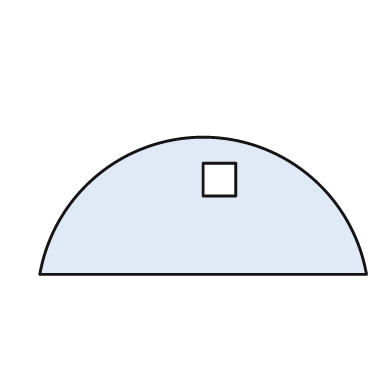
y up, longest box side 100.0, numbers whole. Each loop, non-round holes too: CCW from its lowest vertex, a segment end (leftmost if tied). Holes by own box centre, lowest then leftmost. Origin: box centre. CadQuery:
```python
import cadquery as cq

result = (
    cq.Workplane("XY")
    .moveTo(-50.0, -21.0)
    .lineTo(50.0, -21.0)
    .threePointArc((0.0, 21.0), (-50.0, -21.0))
    .close()
    .moveTo(0.0, 3.0)
    .lineTo(10.0, 3.0)
    .lineTo(10.0, 13.0)
    .lineTo(0.0, 13.0)
    .close()
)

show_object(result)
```